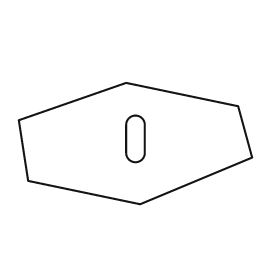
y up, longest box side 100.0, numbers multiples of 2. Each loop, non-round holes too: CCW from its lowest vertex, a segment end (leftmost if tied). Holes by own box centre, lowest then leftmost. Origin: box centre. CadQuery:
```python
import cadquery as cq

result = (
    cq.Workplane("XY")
    .moveTo(2.0, -26.0)
    .lineTo(50.0, -6.0)
    .lineTo(44.0, 16.0)
    .lineTo(-4.0, 26.0)
    .lineTo(-50.0, 10.0)
    .lineTo(-46.0, -16.0)
    .close()
    .moveTo(-4.0, -4.0)
    .threePointArc((0.0, -8.0), (4.0, -4.0))
    .lineTo(4.0, 8.0)
    .threePointArc((0.0, 12.0), (-4.0, 8.0))
    .close()
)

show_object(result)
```